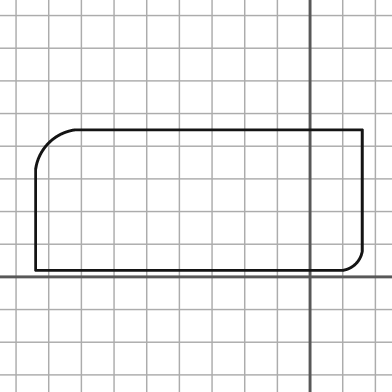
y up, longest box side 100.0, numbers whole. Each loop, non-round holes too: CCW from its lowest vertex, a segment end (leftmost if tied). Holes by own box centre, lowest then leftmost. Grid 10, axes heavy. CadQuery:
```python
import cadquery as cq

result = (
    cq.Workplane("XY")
    .moveTo(-84.0, 2.0)
    .lineTo(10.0, 2.0)
    .threePointArc((14.0, 4.0), (16.0, 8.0))
    .lineTo(16.0, 45.0)
    .lineTo(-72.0, 45.0)
    .threePointArc((-80.0, 41.0), (-84.0, 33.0))
    .close()
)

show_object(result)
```